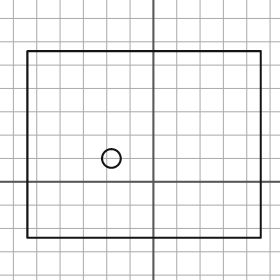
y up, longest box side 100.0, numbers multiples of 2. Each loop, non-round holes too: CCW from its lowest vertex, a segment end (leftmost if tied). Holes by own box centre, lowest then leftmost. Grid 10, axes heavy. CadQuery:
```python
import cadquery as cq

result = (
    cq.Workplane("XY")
    .moveTo(-54.0, -24.0)
    .lineTo(46.0, -24.0)
    .lineTo(46.0, 56.0)
    .lineTo(-54.0, 56.0)
    .close()
    .moveTo(-18.0, 10.0)
    .circle(4.0)
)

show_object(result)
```